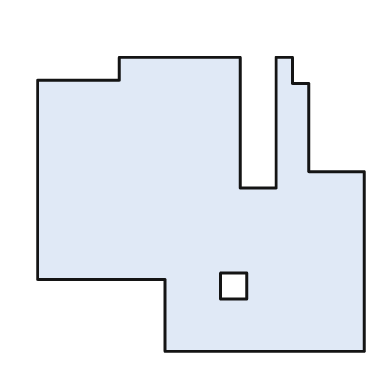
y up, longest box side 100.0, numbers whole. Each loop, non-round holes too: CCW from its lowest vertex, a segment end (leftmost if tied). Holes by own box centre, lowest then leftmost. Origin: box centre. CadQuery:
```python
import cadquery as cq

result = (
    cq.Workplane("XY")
    .moveTo(-11.0, -45.0)
    .lineTo(50.0, -45.0)
    .lineTo(50.0, 10.0)
    .lineTo(33.0, 10.0)
    .lineTo(33.0, 37.0)
    .lineTo(28.0, 37.0)
    .lineTo(28.0, 45.0)
    .lineTo(23.0, 45.0)
    .lineTo(23.0, 5.0)
    .lineTo(12.0, 5.0)
    .lineTo(12.0, 45.0)
    .lineTo(-25.0, 45.0)
    .lineTo(-25.0, 38.0)
    .lineTo(-50.0, 38.0)
    .lineTo(-50.0, -23.0)
    .lineTo(-11.0, -23.0)
    .close()
    .moveTo(6.0, -29.0)
    .lineTo(14.0, -29.0)
    .lineTo(14.0, -21.0)
    .lineTo(6.0, -21.0)
    .close()
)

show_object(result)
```